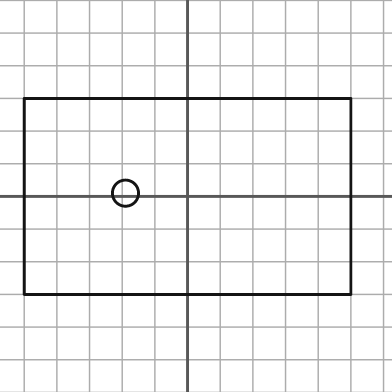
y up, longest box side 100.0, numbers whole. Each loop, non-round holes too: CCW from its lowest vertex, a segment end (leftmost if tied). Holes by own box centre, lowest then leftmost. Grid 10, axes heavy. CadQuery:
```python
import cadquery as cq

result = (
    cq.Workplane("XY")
    .moveTo(-50.0, -30.0)
    .lineTo(50.0, -30.0)
    .lineTo(50.0, 30.0)
    .lineTo(-50.0, 30.0)
    .close()
    .moveTo(-19.0, 1.0)
    .circle(4.0)
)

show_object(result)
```